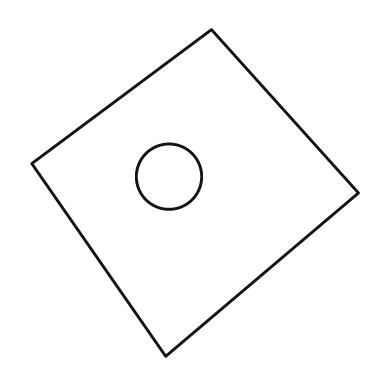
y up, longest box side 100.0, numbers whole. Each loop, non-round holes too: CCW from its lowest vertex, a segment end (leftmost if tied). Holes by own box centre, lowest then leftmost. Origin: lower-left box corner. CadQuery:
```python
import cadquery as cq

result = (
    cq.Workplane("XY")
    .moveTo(41.0, 0.0)
    .lineTo(100.0, 50.0)
    .lineTo(55.0, 100.0)
    .lineTo(0.0, 59.0)
    .close()
    .moveTo(42.0, 55.0)
    .circle(10.0)
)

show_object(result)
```